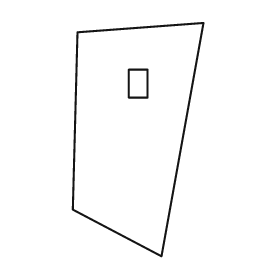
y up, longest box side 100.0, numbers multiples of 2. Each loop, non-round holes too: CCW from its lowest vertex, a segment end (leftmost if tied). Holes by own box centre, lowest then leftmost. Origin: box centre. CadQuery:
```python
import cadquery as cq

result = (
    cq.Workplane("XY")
    .moveTo(10.0, -50.0)
    .lineTo(28.0, 50.0)
    .lineTo(-26.0, 46.0)
    .lineTo(-28.0, -30.0)
    .close()
    .moveTo(-4.0, 18.0)
    .lineTo(4.0, 18.0)
    .lineTo(4.0, 30.0)
    .lineTo(-4.0, 30.0)
    .close()
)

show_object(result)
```